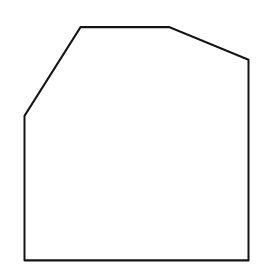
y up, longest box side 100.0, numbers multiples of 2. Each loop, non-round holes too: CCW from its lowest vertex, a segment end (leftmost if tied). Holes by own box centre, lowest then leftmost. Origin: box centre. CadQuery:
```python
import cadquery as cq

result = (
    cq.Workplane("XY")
    .moveTo(-48.0, -50.0)
    .lineTo(48.0, -50.0)
    .lineTo(48.0, 36.0)
    .lineTo(14.0, 50.0)
    .lineTo(-24.0, 50.0)
    .lineTo(-48.0, 12.0)
    .close()
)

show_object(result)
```